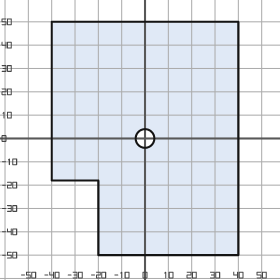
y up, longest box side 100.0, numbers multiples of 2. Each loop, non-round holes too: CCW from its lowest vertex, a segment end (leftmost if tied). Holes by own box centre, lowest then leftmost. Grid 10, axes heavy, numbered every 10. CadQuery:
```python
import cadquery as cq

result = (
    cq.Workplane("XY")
    .moveTo(-20.0, -50.0)
    .lineTo(40.0, -50.0)
    .lineTo(40.0, 50.0)
    .lineTo(-40.0, 50.0)
    .lineTo(-40.0, -18.0)
    .lineTo(-20.0, -18.0)
    .close()
    .moveTo(0.0, 0.0)
    .circle(4.0)
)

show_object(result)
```